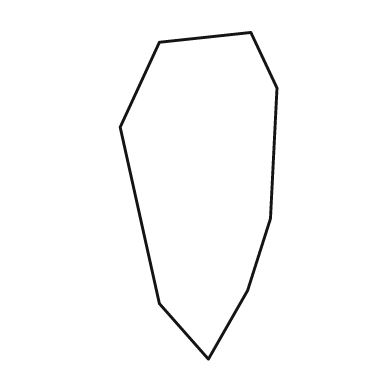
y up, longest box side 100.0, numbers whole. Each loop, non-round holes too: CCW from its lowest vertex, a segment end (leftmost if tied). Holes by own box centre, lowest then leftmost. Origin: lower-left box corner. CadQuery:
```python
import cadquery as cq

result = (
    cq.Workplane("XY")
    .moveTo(27.0, 0.0)
    .lineTo(39.0, 21.0)
    .lineTo(46.0, 43.0)
    .lineTo(48.0, 83.0)
    .lineTo(40.0, 100.0)
    .lineTo(12.0, 97.0)
    .lineTo(0.0, 71.0)
    .lineTo(12.0, 17.0)
    .close()
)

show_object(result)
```